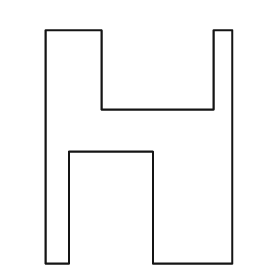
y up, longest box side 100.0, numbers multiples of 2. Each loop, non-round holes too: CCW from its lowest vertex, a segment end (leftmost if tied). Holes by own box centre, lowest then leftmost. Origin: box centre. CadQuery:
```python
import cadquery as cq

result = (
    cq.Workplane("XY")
    .moveTo(-40.0, -50.0)
    .lineTo(-30.0, -50.0)
    .lineTo(-30.0, -2.0)
    .lineTo(6.0, -2.0)
    .lineTo(6.0, -50.0)
    .lineTo(40.0, -50.0)
    .lineTo(40.0, 50.0)
    .lineTo(32.0, 50.0)
    .lineTo(32.0, 16.0)
    .lineTo(-16.0, 16.0)
    .lineTo(-16.0, 50.0)
    .lineTo(-40.0, 50.0)
    .close()
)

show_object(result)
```